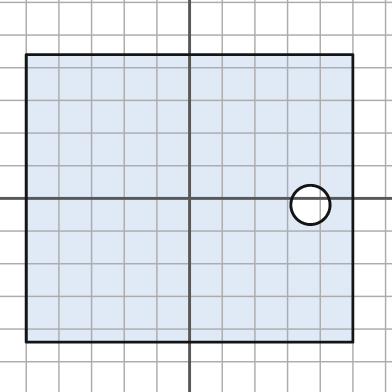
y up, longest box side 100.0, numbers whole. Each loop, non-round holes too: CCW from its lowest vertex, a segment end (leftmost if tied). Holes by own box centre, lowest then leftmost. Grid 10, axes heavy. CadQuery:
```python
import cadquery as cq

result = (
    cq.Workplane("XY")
    .moveTo(-50.0, -44.0)
    .lineTo(50.0, -44.0)
    .lineTo(50.0, 44.0)
    .lineTo(-50.0, 44.0)
    .close()
    .moveTo(37.0, -2.0)
    .circle(6.0)
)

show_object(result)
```